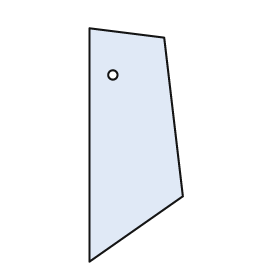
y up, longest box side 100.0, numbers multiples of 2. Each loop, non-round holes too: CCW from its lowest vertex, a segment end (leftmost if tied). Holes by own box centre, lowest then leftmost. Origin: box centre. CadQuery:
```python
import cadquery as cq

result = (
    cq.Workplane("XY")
    .moveTo(-20.0, -50.0)
    .lineTo(20.0, -22.0)
    .lineTo(12.0, 46.0)
    .lineTo(-20.0, 50.0)
    .close()
    .moveTo(-10.0, 30.0)
    .circle(2.0)
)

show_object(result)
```